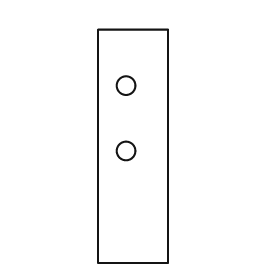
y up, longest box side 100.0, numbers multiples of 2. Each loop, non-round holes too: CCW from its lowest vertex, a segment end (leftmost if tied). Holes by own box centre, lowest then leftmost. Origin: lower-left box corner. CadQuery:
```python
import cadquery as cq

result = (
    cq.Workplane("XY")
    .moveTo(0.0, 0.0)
    .lineTo(30.0, 0.0)
    .lineTo(30.0, 100.0)
    .lineTo(0.0, 100.0)
    .close()
    .moveTo(12.0, 48.0)
    .circle(4.0)
    .moveTo(12.0, 76.0)
    .circle(4.0)
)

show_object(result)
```